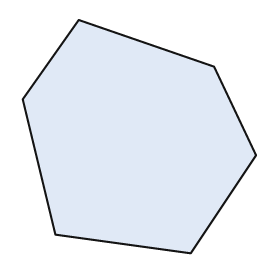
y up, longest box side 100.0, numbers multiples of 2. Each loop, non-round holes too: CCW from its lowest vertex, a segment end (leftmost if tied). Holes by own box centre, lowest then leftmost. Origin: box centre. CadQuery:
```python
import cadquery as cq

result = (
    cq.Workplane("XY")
    .moveTo(22.0, -50.0)
    .lineTo(50.0, -8.0)
    .lineTo(32.0, 30.0)
    .lineTo(-26.0, 50.0)
    .lineTo(-50.0, 16.0)
    .lineTo(-36.0, -42.0)
    .close()
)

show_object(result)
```